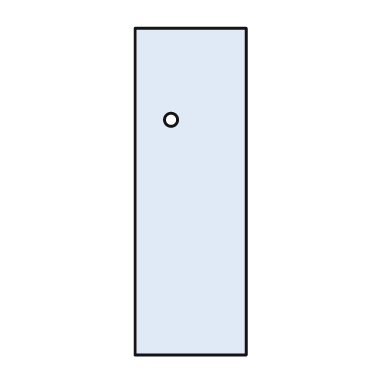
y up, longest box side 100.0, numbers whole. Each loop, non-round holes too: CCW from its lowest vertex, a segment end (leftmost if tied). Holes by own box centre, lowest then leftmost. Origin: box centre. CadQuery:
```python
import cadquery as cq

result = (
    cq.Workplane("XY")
    .moveTo(-17.0, -50.0)
    .lineTo(17.0, -50.0)
    .lineTo(17.0, 50.0)
    .lineTo(-17.0, 50.0)
    .close()
    .moveTo(-6.0, 22.0)
    .circle(2.0)
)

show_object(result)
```